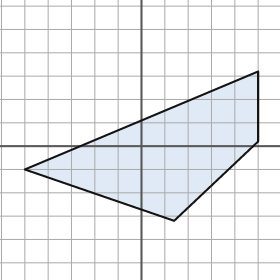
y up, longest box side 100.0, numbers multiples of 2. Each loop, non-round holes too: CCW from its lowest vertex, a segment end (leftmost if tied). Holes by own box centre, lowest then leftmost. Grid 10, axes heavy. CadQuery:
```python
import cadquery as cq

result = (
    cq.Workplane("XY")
    .moveTo(14.0, -32.0)
    .lineTo(50.0, 2.0)
    .lineTo(50.0, 32.0)
    .lineTo(-50.0, -10.0)
    .close()
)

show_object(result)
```